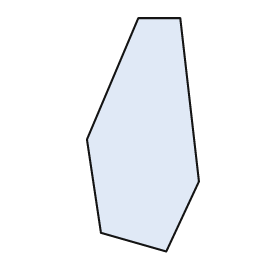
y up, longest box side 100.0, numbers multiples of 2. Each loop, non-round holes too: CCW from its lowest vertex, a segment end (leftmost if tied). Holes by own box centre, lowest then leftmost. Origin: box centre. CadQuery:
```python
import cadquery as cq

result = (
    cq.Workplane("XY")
    .moveTo(10.0, -50.0)
    .lineTo(24.0, -20.0)
    .lineTo(16.0, 50.0)
    .lineTo(-2.0, 50.0)
    .lineTo(-24.0, -2.0)
    .lineTo(-18.0, -42.0)
    .close()
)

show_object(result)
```